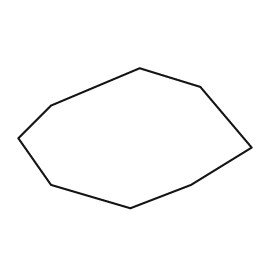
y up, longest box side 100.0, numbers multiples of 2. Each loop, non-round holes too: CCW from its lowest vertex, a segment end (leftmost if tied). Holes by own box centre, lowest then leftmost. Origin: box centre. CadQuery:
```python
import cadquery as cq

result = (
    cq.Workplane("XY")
    .moveTo(-2.0, -30.0)
    .lineTo(24.0, -20.0)
    .lineTo(50.0, -4.0)
    .lineTo(28.0, 22.0)
    .lineTo(2.0, 30.0)
    .lineTo(-36.0, 14.0)
    .lineTo(-50.0, 0.0)
    .lineTo(-36.0, -20.0)
    .close()
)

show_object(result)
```